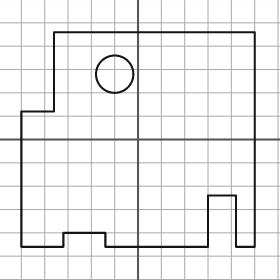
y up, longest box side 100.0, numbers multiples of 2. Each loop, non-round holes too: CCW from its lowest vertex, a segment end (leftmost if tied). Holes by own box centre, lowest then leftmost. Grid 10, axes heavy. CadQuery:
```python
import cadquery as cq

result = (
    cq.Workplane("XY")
    .moveTo(-50.0, -46.0)
    .lineTo(-32.0, -46.0)
    .lineTo(-32.0, -40.0)
    .lineTo(-14.0, -40.0)
    .lineTo(-14.0, -46.0)
    .lineTo(30.0, -46.0)
    .lineTo(30.0, -24.0)
    .lineTo(42.0, -24.0)
    .lineTo(42.0, -46.0)
    .lineTo(50.0, -46.0)
    .lineTo(50.0, 46.0)
    .lineTo(-36.0, 46.0)
    .lineTo(-36.0, 12.0)
    .lineTo(-50.0, 12.0)
    .close()
    .moveTo(-10.0, 28.0)
    .circle(8.0)
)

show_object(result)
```